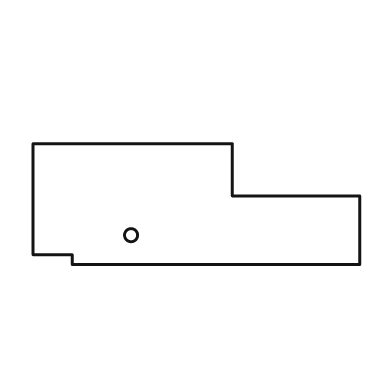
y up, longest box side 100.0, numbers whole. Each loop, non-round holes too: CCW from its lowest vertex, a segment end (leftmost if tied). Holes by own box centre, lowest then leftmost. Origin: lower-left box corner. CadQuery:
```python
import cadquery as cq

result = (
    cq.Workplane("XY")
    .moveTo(12.0, 0.0)
    .lineTo(100.0, 0.0)
    .lineTo(100.0, 21.0)
    .lineTo(61.0, 21.0)
    .lineTo(61.0, 37.0)
    .lineTo(0.0, 37.0)
    .lineTo(0.0, 3.0)
    .lineTo(12.0, 3.0)
    .close()
    .moveTo(30.0, 9.0)
    .circle(2.0)
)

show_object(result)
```